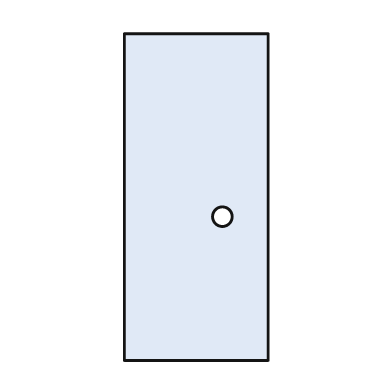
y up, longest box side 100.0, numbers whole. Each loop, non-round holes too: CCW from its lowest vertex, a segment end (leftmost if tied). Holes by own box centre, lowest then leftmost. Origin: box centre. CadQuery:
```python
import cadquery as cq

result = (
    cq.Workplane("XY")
    .moveTo(-22.0, -50.0)
    .lineTo(22.0, -50.0)
    .lineTo(22.0, 50.0)
    .lineTo(-22.0, 50.0)
    .close()
    .moveTo(8.0, -6.0)
    .circle(3.0)
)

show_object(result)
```